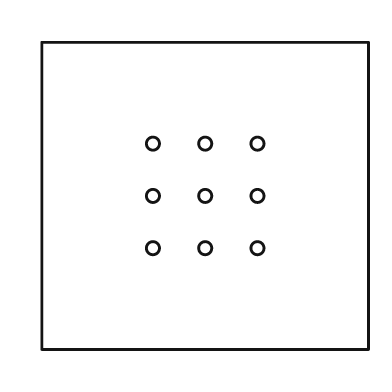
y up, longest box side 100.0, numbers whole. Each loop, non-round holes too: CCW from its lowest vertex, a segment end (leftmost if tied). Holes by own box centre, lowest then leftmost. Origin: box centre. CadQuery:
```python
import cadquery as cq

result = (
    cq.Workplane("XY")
    .moveTo(-50.0, -47.0)
    .lineTo(50.0, -47.0)
    .lineTo(50.0, 47.0)
    .lineTo(-50.0, 47.0)
    .close()
    .moveTo(-16.0, -16.0)
    .circle(2.0)
    .moveTo(0.0, -16.0)
    .circle(2.0)
    .moveTo(16.0, -16.0)
    .circle(2.0)
    .moveTo(-16.0, 0.0)
    .circle(2.0)
    .moveTo(0.0, 0.0)
    .circle(2.0)
    .moveTo(16.0, 0.0)
    .circle(2.0)
    .moveTo(-16.0, 16.0)
    .circle(2.0)
    .moveTo(0.0, 16.0)
    .circle(2.0)
    .moveTo(16.0, 16.0)
    .circle(2.0)
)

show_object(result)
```